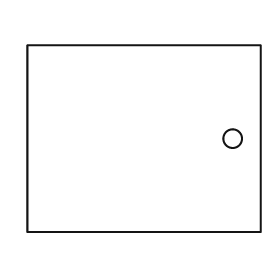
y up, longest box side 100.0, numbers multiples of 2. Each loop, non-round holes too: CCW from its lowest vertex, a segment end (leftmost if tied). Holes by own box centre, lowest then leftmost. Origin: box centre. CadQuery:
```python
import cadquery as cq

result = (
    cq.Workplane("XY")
    .moveTo(-50.0, -40.0)
    .lineTo(50.0, -40.0)
    .lineTo(50.0, 40.0)
    .lineTo(-50.0, 40.0)
    .close()
    .moveTo(38.0, 0.0)
    .circle(4.0)
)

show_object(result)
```